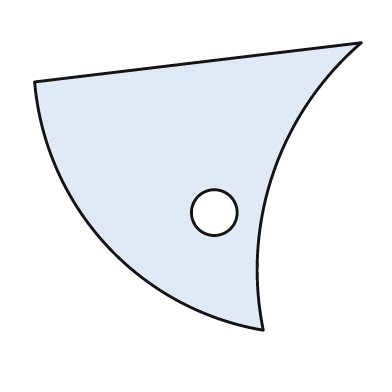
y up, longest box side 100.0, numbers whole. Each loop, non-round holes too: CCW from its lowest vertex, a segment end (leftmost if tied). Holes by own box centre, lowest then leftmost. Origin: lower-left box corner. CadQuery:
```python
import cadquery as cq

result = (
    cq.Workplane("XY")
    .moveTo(70.0, 0.0)
    .threePointArc((73.0, 48.0), (100.0, 88.0))
    .lineTo(0.0, 76.0)
    .threePointArc((22.0, 26.0), (70.0, 0.0))
    .close()
    .moveTo(55.0, 36.0)
    .circle(7.0)
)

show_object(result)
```